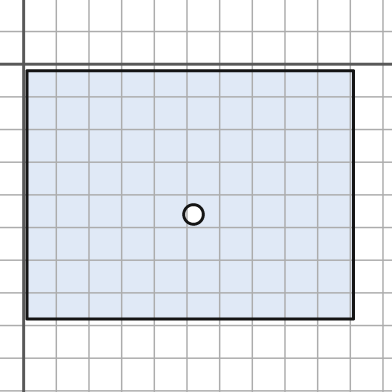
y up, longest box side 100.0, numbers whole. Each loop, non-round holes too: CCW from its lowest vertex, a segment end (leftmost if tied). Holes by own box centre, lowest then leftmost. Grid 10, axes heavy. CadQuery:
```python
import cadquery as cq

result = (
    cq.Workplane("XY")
    .moveTo(1.0, -78.0)
    .lineTo(101.0, -78.0)
    .lineTo(101.0, -2.0)
    .lineTo(1.0, -2.0)
    .close()
    .moveTo(52.0, -46.0)
    .circle(3.0)
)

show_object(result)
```